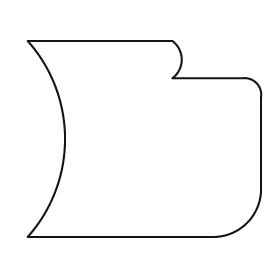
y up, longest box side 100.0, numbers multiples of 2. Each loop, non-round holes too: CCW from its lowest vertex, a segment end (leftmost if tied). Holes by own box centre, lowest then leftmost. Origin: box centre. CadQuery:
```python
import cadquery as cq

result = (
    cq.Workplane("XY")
    .moveTo(-50.0, -42.0)
    .lineTo(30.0, -42.0)
    .threePointArc((44.0, -36.0), (50.0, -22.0))
    .lineTo(50.0, 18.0)
    .threePointArc((48.0, 24.0), (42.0, 26.0))
    .lineTo(12.0, 26.0)
    .threePointArc((16.0, 34.0), (12.0, 42.0))
    .lineTo(-50.0, 42.0)
    .threePointArc((-34.0, 0.0), (-50.0, -42.0))
    .close()
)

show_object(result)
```